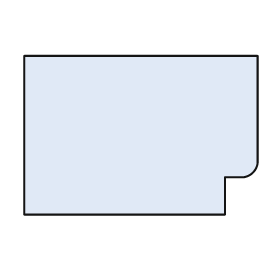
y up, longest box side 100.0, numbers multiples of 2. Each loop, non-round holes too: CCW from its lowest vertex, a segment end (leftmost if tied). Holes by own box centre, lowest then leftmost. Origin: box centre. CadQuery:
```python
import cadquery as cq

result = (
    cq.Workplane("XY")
    .moveTo(-50.0, -34.0)
    .lineTo(36.0, -34.0)
    .lineTo(36.0, -18.0)
    .lineTo(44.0, -18.0)
    .threePointArc((48.0, -16.0), (50.0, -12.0))
    .lineTo(50.0, 34.0)
    .lineTo(-50.0, 34.0)
    .close()
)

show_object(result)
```